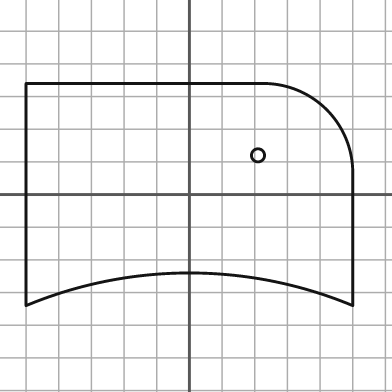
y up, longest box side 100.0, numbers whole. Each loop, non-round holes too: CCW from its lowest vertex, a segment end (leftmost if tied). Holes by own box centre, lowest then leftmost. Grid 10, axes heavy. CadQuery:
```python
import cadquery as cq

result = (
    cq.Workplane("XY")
    .moveTo(-50.0, -34.0)
    .threePointArc((0.0, -24.0), (50.0, -34.0))
    .lineTo(50.0, 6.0)
    .threePointArc((42.0, 26.0), (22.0, 34.0))
    .lineTo(-50.0, 34.0)
    .close()
    .moveTo(21.0, 12.0)
    .circle(2.0)
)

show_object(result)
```